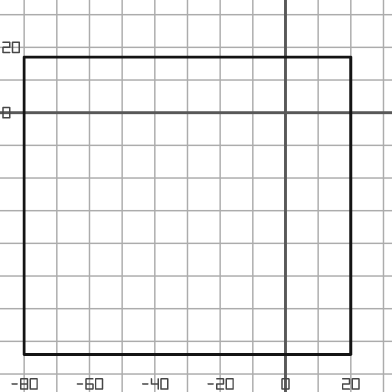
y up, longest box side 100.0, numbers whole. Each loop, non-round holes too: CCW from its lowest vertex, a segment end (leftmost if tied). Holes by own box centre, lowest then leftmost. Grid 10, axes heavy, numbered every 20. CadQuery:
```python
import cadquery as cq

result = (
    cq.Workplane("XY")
    .moveTo(-80.0, -74.0)
    .lineTo(20.0, -74.0)
    .lineTo(20.0, 17.0)
    .lineTo(-80.0, 17.0)
    .close()
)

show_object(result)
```